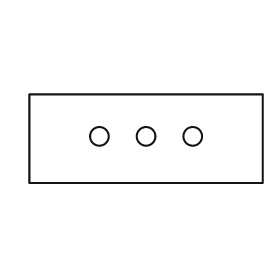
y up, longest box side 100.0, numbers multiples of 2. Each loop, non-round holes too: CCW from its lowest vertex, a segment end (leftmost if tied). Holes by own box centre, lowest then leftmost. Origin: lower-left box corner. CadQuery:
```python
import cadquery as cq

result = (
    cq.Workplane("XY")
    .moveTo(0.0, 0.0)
    .lineTo(100.0, 0.0)
    .lineTo(100.0, 38.0)
    .lineTo(0.0, 38.0)
    .close()
    .moveTo(30.0, 20.0)
    .circle(4.0)
    .moveTo(50.0, 20.0)
    .circle(4.0)
    .moveTo(70.0, 20.0)
    .circle(4.0)
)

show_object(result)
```